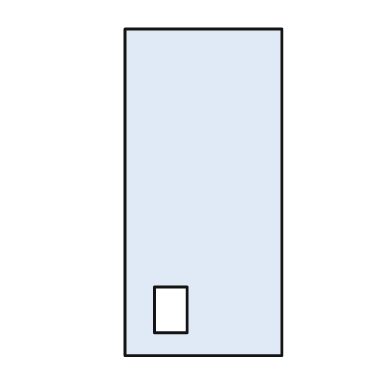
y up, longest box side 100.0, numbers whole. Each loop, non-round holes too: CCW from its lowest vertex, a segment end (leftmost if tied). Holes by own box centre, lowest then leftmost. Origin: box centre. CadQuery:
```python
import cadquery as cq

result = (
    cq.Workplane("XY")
    .moveTo(-24.0, -50.0)
    .lineTo(24.0, -50.0)
    .lineTo(24.0, 50.0)
    .lineTo(-24.0, 50.0)
    .close()
    .moveTo(-15.0, -43.0)
    .lineTo(-5.0, -43.0)
    .lineTo(-5.0, -29.0)
    .lineTo(-15.0, -29.0)
    .close()
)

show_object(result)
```